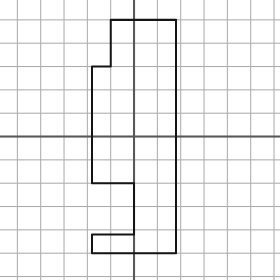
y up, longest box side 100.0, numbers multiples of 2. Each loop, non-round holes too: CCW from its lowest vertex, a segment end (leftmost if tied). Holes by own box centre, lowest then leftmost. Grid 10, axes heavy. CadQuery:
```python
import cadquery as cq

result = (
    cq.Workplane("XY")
    .moveTo(-18.0, -50.0)
    .lineTo(18.0, -50.0)
    .lineTo(18.0, 50.0)
    .lineTo(-10.0, 50.0)
    .lineTo(-10.0, 30.0)
    .lineTo(-18.0, 30.0)
    .lineTo(-18.0, -20.0)
    .lineTo(0.0, -20.0)
    .lineTo(0.0, -42.0)
    .lineTo(-18.0, -42.0)
    .close()
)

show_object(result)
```